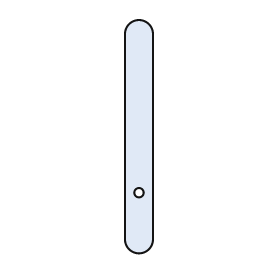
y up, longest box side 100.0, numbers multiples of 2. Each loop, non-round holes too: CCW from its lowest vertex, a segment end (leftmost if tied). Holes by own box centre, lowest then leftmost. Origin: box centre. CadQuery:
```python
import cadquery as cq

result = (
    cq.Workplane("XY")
    .moveTo(-6.0, -44.0)
    .threePointArc((0.0, -50.0), (6.0, -44.0))
    .lineTo(6.0, 44.0)
    .threePointArc((0.0, 50.0), (-6.0, 44.0))
    .close()
    .moveTo(0.0, -24.0)
    .circle(2.0)
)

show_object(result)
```